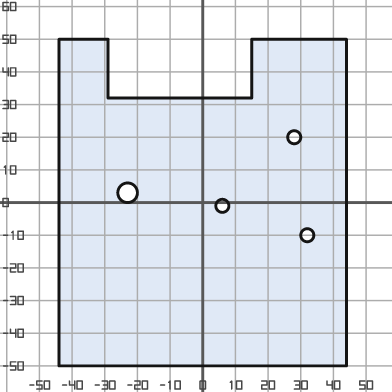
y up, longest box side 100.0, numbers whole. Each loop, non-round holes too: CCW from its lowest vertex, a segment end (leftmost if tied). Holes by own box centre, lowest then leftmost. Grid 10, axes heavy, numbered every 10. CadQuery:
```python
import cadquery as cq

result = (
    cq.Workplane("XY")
    .moveTo(-44.0, -50.0)
    .lineTo(44.0, -50.0)
    .lineTo(44.0, 50.0)
    .lineTo(15.0, 50.0)
    .lineTo(15.0, 32.0)
    .lineTo(-29.0, 32.0)
    .lineTo(-29.0, 50.0)
    .lineTo(-44.0, 50.0)
    .close()
    .moveTo(32.0, -10.0)
    .circle(2.0)
    .moveTo(6.0, -1.0)
    .circle(2.0)
    .moveTo(-23.0, 3.0)
    .circle(3.0)
    .moveTo(28.0, 20.0)
    .circle(2.0)
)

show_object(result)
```